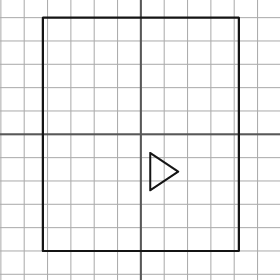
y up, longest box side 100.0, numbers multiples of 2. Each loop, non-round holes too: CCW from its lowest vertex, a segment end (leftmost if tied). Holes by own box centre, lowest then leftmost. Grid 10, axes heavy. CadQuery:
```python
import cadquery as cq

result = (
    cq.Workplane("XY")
    .moveTo(-42.0, -50.0)
    .lineTo(42.0, -50.0)
    .lineTo(42.0, 50.0)
    .lineTo(-42.0, 50.0)
    .close()
    .moveTo(4.0, -24.0)
    .lineTo(16.0, -16.0)
    .lineTo(4.0, -8.0)
    .close()
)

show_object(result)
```